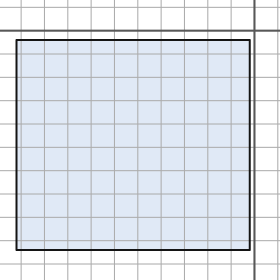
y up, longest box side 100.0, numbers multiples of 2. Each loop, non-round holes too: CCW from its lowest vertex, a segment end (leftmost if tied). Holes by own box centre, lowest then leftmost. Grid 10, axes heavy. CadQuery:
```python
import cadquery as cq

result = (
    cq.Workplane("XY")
    .moveTo(-102.0, -94.0)
    .lineTo(-2.0, -94.0)
    .lineTo(-2.0, -4.0)
    .lineTo(-102.0, -4.0)
    .close()
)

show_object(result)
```